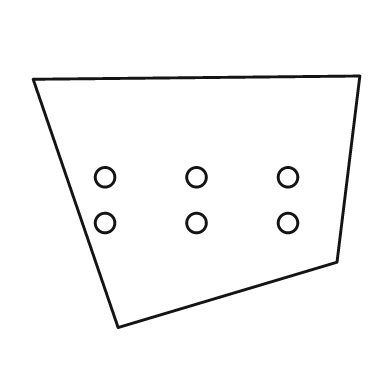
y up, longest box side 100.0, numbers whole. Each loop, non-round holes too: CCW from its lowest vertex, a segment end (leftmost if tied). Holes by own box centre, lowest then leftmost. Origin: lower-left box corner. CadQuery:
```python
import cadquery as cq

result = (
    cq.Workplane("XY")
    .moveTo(26.0, 0.0)
    .lineTo(93.0, 20.0)
    .lineTo(100.0, 77.0)
    .lineTo(0.0, 76.0)
    .close()
    .moveTo(22.0, 32.0)
    .circle(3.0)
    .moveTo(50.0, 32.0)
    .circle(3.0)
    .moveTo(78.0, 32.0)
    .circle(3.0)
    .moveTo(22.0, 46.0)
    .circle(3.0)
    .moveTo(50.0, 46.0)
    .circle(3.0)
    .moveTo(78.0, 46.0)
    .circle(3.0)
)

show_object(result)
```